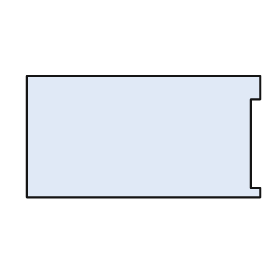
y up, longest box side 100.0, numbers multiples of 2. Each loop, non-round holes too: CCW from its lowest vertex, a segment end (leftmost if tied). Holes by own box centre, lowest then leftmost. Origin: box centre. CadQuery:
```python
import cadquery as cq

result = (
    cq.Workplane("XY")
    .moveTo(-50.0, -26.0)
    .lineTo(50.0, -26.0)
    .lineTo(50.0, -22.0)
    .lineTo(46.0, -22.0)
    .lineTo(46.0, 16.0)
    .lineTo(50.0, 16.0)
    .lineTo(50.0, 26.0)
    .lineTo(-50.0, 26.0)
    .close()
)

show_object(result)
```